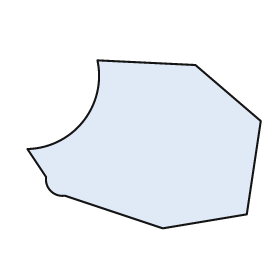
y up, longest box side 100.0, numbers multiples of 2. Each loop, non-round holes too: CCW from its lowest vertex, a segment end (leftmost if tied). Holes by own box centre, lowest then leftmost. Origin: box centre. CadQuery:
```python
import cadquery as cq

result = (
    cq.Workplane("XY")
    .moveTo(8.0, -36.0)
    .lineTo(44.0, -30.0)
    .lineTo(50.0, 10.0)
    .lineTo(22.0, 34.0)
    .lineTo(-20.0, 36.0)
    .threePointArc((-26.0, 10.0), (-50.0, -2.0))
    .lineTo(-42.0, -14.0)
    .threePointArc((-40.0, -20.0), (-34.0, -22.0))
    .close()
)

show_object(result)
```